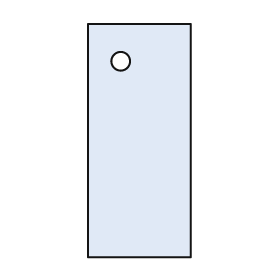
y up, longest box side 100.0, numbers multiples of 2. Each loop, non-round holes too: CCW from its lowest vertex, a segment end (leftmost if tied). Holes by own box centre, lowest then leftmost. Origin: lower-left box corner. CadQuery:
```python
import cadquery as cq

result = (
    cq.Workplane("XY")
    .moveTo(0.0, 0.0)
    .lineTo(44.0, 0.0)
    .lineTo(44.0, 100.0)
    .lineTo(0.0, 100.0)
    .close()
    .moveTo(14.0, 84.0)
    .circle(4.0)
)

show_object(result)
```